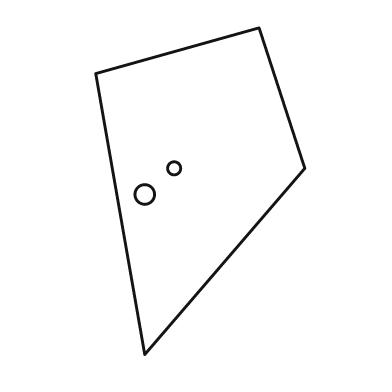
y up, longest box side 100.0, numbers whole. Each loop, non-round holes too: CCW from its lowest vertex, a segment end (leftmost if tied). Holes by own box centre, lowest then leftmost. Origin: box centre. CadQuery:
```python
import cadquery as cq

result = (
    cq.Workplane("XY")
    .moveTo(-17.0, -50.0)
    .lineTo(32.0, 7.0)
    .lineTo(18.0, 50.0)
    .lineTo(-32.0, 36.0)
    .close()
    .moveTo(-17.0, -1.0)
    .circle(3.0)
    .moveTo(-8.0, 7.0)
    .circle(2.0)
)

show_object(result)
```